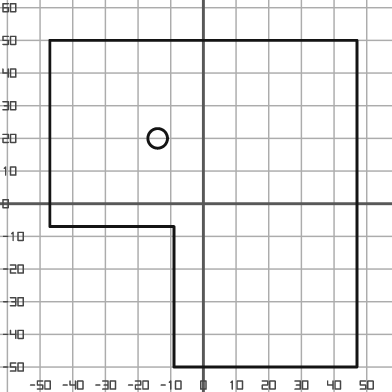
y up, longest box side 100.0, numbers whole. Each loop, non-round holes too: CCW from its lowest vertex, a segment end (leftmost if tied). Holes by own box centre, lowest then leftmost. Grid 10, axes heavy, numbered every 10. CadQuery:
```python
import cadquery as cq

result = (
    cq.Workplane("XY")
    .moveTo(-9.0, -50.0)
    .lineTo(47.0, -50.0)
    .lineTo(47.0, 50.0)
    .lineTo(-47.0, 50.0)
    .lineTo(-47.0, -7.0)
    .lineTo(-9.0, -7.0)
    .close()
    .moveTo(-14.0, 20.0)
    .circle(3.0)
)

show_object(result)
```